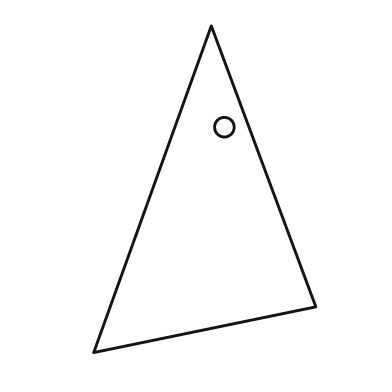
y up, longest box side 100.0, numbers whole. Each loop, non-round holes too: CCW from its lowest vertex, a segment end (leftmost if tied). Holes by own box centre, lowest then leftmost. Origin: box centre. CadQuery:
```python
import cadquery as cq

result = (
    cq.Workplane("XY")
    .moveTo(-34.0, -50.0)
    .lineTo(34.0, -36.0)
    .lineTo(2.0, 50.0)
    .close()
    .moveTo(6.0, 19.0)
    .circle(3.0)
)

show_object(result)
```